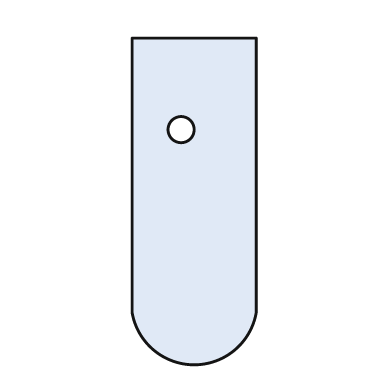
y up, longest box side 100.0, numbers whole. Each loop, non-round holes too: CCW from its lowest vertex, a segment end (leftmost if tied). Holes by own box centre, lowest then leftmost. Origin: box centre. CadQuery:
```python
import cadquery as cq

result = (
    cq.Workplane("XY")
    .moveTo(-19.0, -34.0)
    .threePointArc((0.0, -50.0), (19.0, -34.0))
    .lineTo(19.0, 50.0)
    .lineTo(-19.0, 50.0)
    .close()
    .moveTo(-4.0, 22.0)
    .circle(4.0)
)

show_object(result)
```